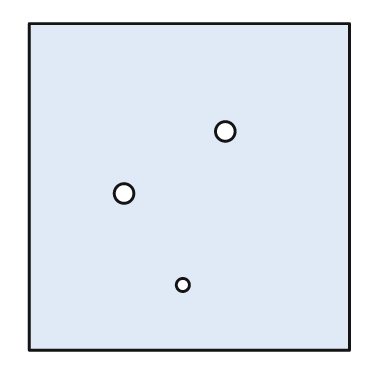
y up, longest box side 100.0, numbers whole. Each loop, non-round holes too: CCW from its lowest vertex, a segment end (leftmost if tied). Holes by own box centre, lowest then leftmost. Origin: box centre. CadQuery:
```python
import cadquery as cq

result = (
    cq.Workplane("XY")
    .moveTo(-49.0, -50.0)
    .lineTo(49.0, -50.0)
    .lineTo(49.0, 50.0)
    .lineTo(-49.0, 50.0)
    .close()
    .moveTo(-2.0, -30.0)
    .circle(2.0)
    .moveTo(-20.0, -2.0)
    .circle(3.0)
    .moveTo(11.0, 17.0)
    .circle(3.0)
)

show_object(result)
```